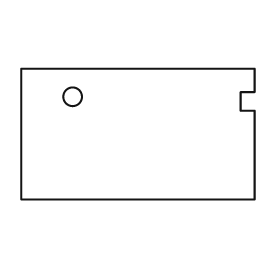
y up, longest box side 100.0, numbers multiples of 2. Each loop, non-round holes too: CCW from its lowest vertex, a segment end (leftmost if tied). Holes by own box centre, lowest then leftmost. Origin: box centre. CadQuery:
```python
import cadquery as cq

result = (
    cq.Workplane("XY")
    .moveTo(-50.0, -28.0)
    .lineTo(50.0, -28.0)
    .lineTo(50.0, 10.0)
    .lineTo(44.0, 10.0)
    .lineTo(44.0, 18.0)
    .lineTo(50.0, 18.0)
    .lineTo(50.0, 28.0)
    .lineTo(-50.0, 28.0)
    .close()
    .moveTo(-28.0, 16.0)
    .circle(4.0)
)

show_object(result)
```